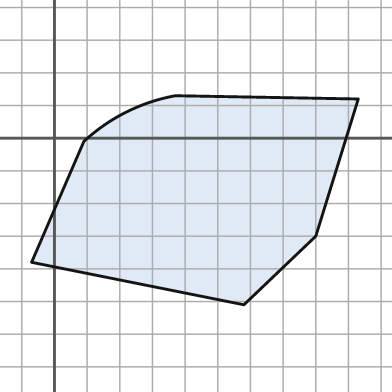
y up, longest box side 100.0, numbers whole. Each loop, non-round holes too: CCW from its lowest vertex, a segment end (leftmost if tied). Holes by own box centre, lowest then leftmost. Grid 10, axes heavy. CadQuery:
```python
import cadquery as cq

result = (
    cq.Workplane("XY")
    .moveTo(58.0, -51.0)
    .lineTo(80.0, -30.0)
    .lineTo(93.0, 12.0)
    .lineTo(37.0, 13.0)
    .threePointArc((22.0, 8.0), (9.0, -1.0))
    .lineTo(-7.0, -38.0)
    .close()
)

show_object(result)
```